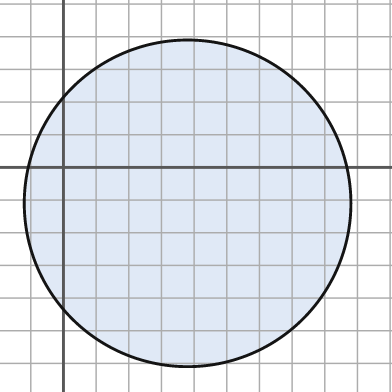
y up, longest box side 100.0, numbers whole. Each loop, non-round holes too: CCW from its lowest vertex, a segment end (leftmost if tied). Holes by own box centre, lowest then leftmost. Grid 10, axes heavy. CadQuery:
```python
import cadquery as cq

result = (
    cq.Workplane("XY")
    .moveTo(38.0, -11.0)
    .circle(50.0)
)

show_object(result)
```